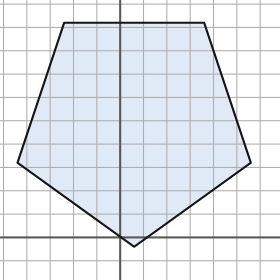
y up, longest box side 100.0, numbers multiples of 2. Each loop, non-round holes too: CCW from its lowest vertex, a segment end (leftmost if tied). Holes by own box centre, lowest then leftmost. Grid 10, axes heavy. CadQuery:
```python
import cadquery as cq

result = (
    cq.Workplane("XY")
    .moveTo(6.0, -4.0)
    .lineTo(56.0, 32.0)
    .lineTo(36.0, 92.0)
    .lineTo(-24.0, 92.0)
    .lineTo(-44.0, 32.0)
    .close()
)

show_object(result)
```